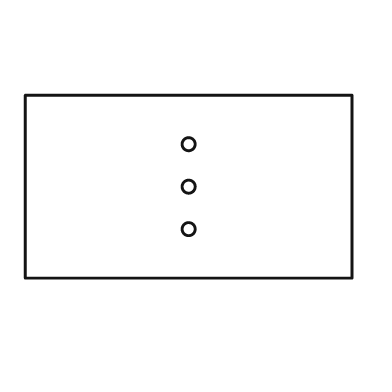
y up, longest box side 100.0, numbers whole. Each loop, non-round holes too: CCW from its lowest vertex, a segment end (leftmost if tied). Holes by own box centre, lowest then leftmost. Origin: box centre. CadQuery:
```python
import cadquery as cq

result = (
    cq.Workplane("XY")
    .moveTo(-50.0, -28.0)
    .lineTo(50.0, -28.0)
    .lineTo(50.0, 28.0)
    .lineTo(-50.0, 28.0)
    .close()
    .moveTo(0.0, -13.0)
    .circle(2.0)
    .moveTo(0.0, 0.0)
    .circle(2.0)
    .moveTo(0.0, 13.0)
    .circle(2.0)
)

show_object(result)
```